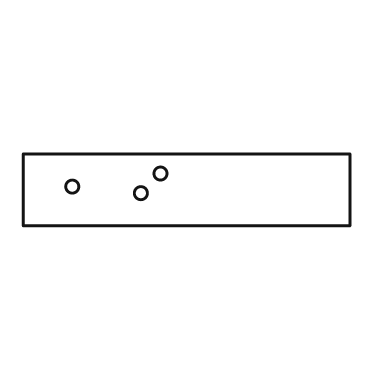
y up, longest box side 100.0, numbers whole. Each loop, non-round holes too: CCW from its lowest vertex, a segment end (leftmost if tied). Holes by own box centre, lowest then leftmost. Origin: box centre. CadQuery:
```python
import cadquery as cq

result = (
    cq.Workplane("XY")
    .moveTo(-50.0, -11.0)
    .lineTo(50.0, -11.0)
    .lineTo(50.0, 11.0)
    .lineTo(-50.0, 11.0)
    .close()
    .moveTo(-14.0, -1.0)
    .circle(2.0)
    .moveTo(-35.0, 1.0)
    .circle(2.0)
    .moveTo(-8.0, 5.0)
    .circle(2.0)
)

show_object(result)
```